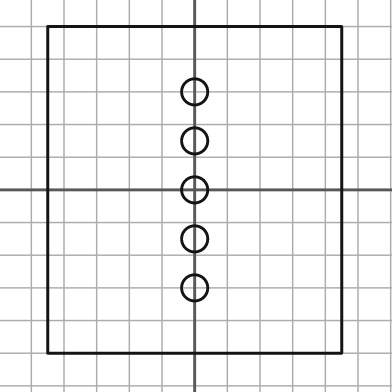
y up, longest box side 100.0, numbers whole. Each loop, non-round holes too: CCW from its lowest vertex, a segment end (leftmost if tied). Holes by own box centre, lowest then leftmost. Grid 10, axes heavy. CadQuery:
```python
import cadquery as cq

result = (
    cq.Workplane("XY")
    .moveTo(-45.0, -50.0)
    .lineTo(45.0, -50.0)
    .lineTo(45.0, 50.0)
    .lineTo(-45.0, 50.0)
    .close()
    .moveTo(0.0, -30.0)
    .circle(4.0)
    .moveTo(0.0, -15.0)
    .circle(4.0)
    .moveTo(0.0, 0.0)
    .circle(4.0)
    .moveTo(0.0, 15.0)
    .circle(4.0)
    .moveTo(0.0, 30.0)
    .circle(4.0)
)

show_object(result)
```